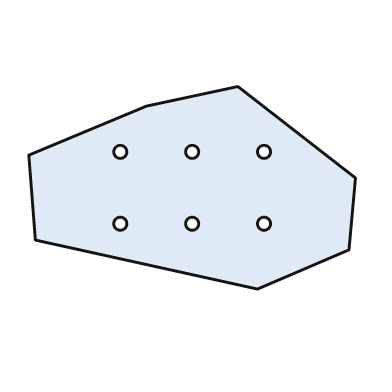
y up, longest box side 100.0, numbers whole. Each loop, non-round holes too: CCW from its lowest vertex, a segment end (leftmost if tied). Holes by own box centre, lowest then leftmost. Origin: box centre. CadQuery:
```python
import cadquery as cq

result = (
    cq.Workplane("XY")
    .moveTo(20.0, -31.0)
    .lineTo(48.0, -19.0)
    .lineTo(50.0, 3.0)
    .lineTo(14.0, 31.0)
    .lineTo(-14.0, 25.0)
    .lineTo(-50.0, 10.0)
    .lineTo(-48.0, -16.0)
    .close()
    .moveTo(-22.0, -11.0)
    .circle(2.0)
    .moveTo(0.0, -11.0)
    .circle(2.0)
    .moveTo(22.0, -11.0)
    .circle(2.0)
    .moveTo(-22.0, 11.0)
    .circle(2.0)
    .moveTo(0.0, 11.0)
    .circle(2.0)
    .moveTo(22.0, 11.0)
    .circle(2.0)
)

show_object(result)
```